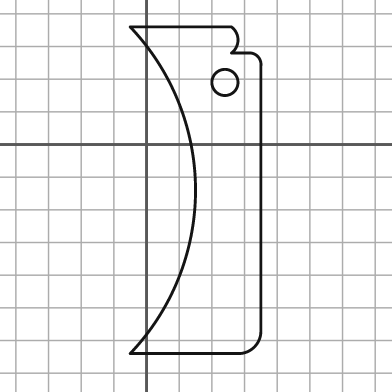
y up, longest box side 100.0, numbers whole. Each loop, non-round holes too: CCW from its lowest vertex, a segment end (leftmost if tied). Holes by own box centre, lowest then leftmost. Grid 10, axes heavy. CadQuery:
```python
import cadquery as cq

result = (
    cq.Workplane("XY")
    .moveTo(-5.0, -64.0)
    .lineTo(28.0, -64.0)
    .threePointArc((33.0, -62.0), (35.0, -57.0))
    .lineTo(35.0, 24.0)
    .threePointArc((34.0, 27.0), (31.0, 28.0))
    .lineTo(26.0, 28.0)
    .threePointArc((28.0, 32.0), (26.0, 36.0))
    .lineTo(-5.0, 36.0)
    .threePointArc((15.0, -14.0), (-5.0, -64.0))
    .close()
    .moveTo(24.0, 19.0)
    .circle(4.0)
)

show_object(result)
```